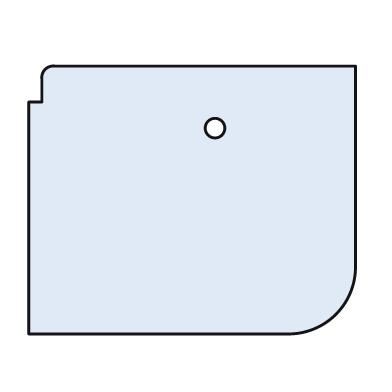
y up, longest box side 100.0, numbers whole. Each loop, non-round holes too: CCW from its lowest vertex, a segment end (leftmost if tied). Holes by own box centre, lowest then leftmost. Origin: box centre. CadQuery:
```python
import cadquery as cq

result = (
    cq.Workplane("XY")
    .moveTo(-50.0, -41.0)
    .lineTo(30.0, -41.0)
    .threePointArc((44.0, -35.0), (50.0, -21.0))
    .lineTo(50.0, 41.0)
    .lineTo(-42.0, 41.0)
    .threePointArc((-45.0, 40.0), (-46.0, 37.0))
    .lineTo(-46.0, 30.0)
    .lineTo(-50.0, 30.0)
    .close()
    .moveTo(7.0, 22.0)
    .circle(3.0)
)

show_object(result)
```